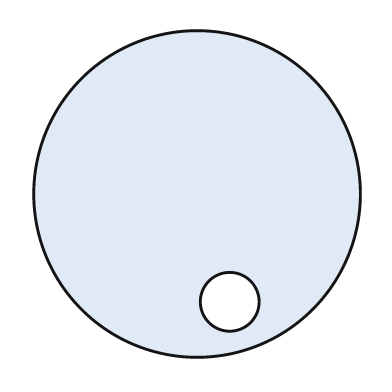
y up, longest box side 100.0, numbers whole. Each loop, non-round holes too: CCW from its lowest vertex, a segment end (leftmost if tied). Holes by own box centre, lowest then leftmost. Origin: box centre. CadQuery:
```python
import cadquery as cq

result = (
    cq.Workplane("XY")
    .moveTo(0.0, 0.0)
    .circle(50.0)
    .moveTo(10.0, -33.0)
    .circle(9.0)
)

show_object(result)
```